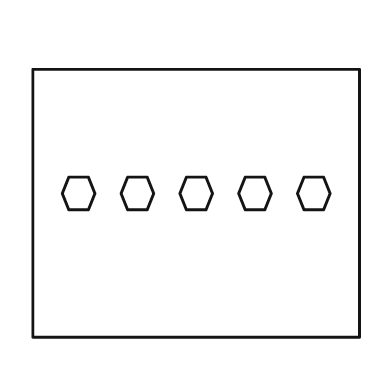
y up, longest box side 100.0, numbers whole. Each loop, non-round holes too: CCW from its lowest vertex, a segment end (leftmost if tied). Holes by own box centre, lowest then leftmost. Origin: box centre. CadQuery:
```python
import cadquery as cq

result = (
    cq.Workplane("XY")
    .moveTo(-50.0, -41.0)
    .lineTo(50.0, -41.0)
    .lineTo(50.0, 41.0)
    .lineTo(-50.0, 41.0)
    .close()
    .moveTo(-39.0, -2.0)
    .lineTo(-33.0, -2.0)
    .lineTo(-31.0, 3.0)
    .lineTo(-33.0, 8.0)
    .lineTo(-39.0, 8.0)
    .lineTo(-41.0, 3.0)
    .close()
    .moveTo(-21.0, -2.0)
    .lineTo(-15.0, -2.0)
    .lineTo(-13.0, 3.0)
    .lineTo(-15.0, 8.0)
    .lineTo(-21.0, 8.0)
    .lineTo(-23.0, 3.0)
    .close()
    .moveTo(-3.0, -2.0)
    .lineTo(3.0, -2.0)
    .lineTo(5.0, 3.0)
    .lineTo(3.0, 8.0)
    .lineTo(-3.0, 8.0)
    .lineTo(-5.0, 3.0)
    .close()
    .moveTo(15.0, -2.0)
    .lineTo(21.0, -2.0)
    .lineTo(23.0, 3.0)
    .lineTo(21.0, 8.0)
    .lineTo(15.0, 8.0)
    .lineTo(13.0, 3.0)
    .close()
    .moveTo(33.0, -2.0)
    .lineTo(39.0, -2.0)
    .lineTo(41.0, 3.0)
    .lineTo(39.0, 8.0)
    .lineTo(33.0, 8.0)
    .lineTo(31.0, 3.0)
    .close()
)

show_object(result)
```